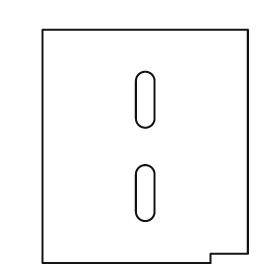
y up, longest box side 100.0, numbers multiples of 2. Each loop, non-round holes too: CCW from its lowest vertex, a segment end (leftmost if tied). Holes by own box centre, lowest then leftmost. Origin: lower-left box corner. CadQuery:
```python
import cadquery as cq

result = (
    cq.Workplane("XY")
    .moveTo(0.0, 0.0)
    .lineTo(72.0, 0.0)
    .lineTo(72.0, 4.0)
    .lineTo(88.0, 4.0)
    .lineTo(88.0, 100.0)
    .lineTo(0.0, 100.0)
    .close()
    .moveTo(40.0, 22.0)
    .threePointArc((44.0, 18.0), (48.0, 22.0))
    .lineTo(48.0, 38.0)
    .threePointArc((44.0, 42.0), (40.0, 38.0))
    .close()
    .moveTo(40.0, 62.0)
    .threePointArc((44.0, 58.0), (48.0, 62.0))
    .lineTo(48.0, 78.0)
    .threePointArc((44.0, 82.0), (40.0, 78.0))
    .close()
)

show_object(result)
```